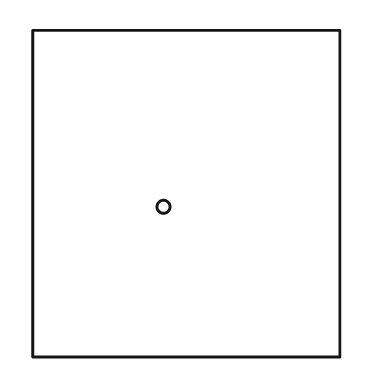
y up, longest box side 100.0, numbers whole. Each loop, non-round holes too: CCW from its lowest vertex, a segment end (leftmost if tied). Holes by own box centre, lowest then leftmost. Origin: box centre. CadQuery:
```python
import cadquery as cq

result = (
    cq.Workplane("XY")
    .moveTo(-47.0, -50.0)
    .lineTo(47.0, -50.0)
    .lineTo(47.0, 50.0)
    .lineTo(-47.0, 50.0)
    .close()
    .moveTo(-7.0, -4.0)
    .circle(2.0)
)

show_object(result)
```